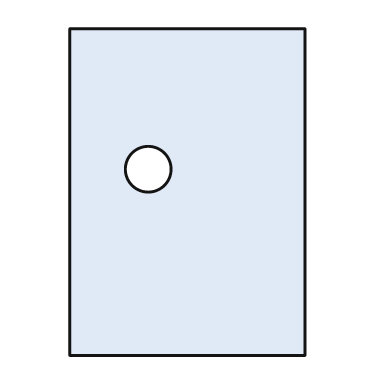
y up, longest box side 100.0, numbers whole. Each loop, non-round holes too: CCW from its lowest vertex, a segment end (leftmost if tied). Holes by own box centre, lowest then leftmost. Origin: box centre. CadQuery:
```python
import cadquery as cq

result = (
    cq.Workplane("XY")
    .moveTo(-36.0, -50.0)
    .lineTo(36.0, -50.0)
    .lineTo(36.0, 50.0)
    .lineTo(-36.0, 50.0)
    .close()
    .moveTo(-12.0, 7.0)
    .circle(7.0)
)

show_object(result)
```